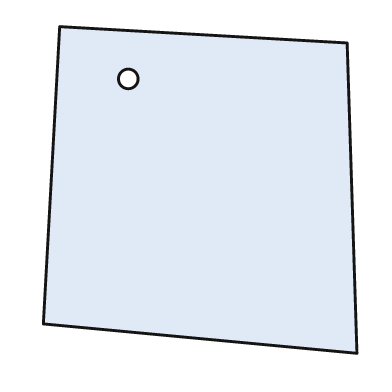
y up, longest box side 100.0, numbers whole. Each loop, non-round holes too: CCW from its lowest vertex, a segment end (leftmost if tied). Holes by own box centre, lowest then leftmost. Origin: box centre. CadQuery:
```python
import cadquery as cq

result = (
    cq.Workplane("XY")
    .moveTo(48.0, -50.0)
    .lineTo(45.0, 45.0)
    .lineTo(-43.0, 50.0)
    .lineTo(-48.0, -41.0)
    .close()
    .moveTo(-22.0, 34.0)
    .circle(3.0)
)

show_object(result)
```